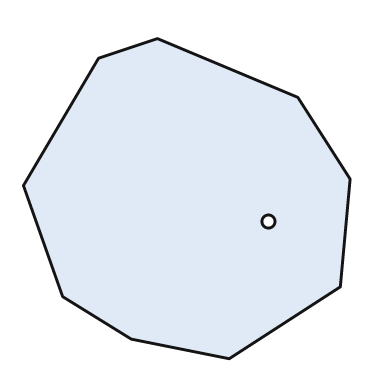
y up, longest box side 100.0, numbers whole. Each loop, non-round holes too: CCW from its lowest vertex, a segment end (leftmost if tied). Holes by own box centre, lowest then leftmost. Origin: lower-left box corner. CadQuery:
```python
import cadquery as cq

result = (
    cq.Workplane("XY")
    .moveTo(63.0, 0.0)
    .lineTo(97.0, 22.0)
    .lineTo(100.0, 55.0)
    .lineTo(84.0, 80.0)
    .lineTo(41.0, 98.0)
    .lineTo(23.0, 92.0)
    .lineTo(0.0, 53.0)
    .lineTo(12.0, 19.0)
    .lineTo(33.0, 6.0)
    .close()
    .moveTo(75.0, 42.0)
    .circle(2.0)
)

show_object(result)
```